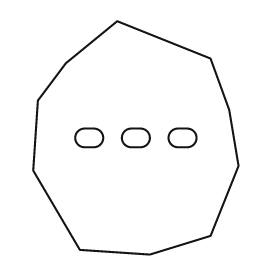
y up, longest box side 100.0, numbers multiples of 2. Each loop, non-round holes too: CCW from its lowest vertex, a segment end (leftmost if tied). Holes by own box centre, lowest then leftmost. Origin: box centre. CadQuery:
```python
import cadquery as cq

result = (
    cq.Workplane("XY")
    .moveTo(6.0, -50.0)
    .lineTo(32.0, -42.0)
    .lineTo(44.0, -12.0)
    .lineTo(40.0, 12.0)
    .lineTo(32.0, 34.0)
    .lineTo(-8.0, 50.0)
    .lineTo(-30.0, 32.0)
    .lineTo(-42.0, 16.0)
    .lineTo(-44.0, -14.0)
    .lineTo(-24.0, -48.0)
    .close()
    .moveTo(-22.0, -4.0)
    .lineTo(-18.0, -4.0)
    .threePointArc((-14.0, 0.0), (-18.0, 4.0))
    .lineTo(-22.0, 4.0)
    .threePointArc((-26.0, 0.0), (-22.0, -4.0))
    .close()
    .moveTo(-2.0, -4.0)
    .lineTo(2.0, -4.0)
    .threePointArc((6.0, 0.0), (2.0, 4.0))
    .lineTo(-2.0, 4.0)
    .threePointArc((-6.0, 0.0), (-2.0, -4.0))
    .close()
    .moveTo(18.0, -4.0)
    .lineTo(22.0, -4.0)
    .threePointArc((26.0, 0.0), (22.0, 4.0))
    .lineTo(18.0, 4.0)
    .threePointArc((14.0, 0.0), (18.0, -4.0))
    .close()
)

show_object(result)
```